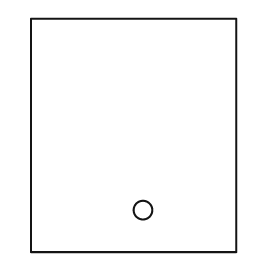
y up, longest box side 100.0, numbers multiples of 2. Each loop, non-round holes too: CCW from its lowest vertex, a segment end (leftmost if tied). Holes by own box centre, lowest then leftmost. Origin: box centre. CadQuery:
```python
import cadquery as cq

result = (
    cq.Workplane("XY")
    .moveTo(-44.0, -50.0)
    .lineTo(44.0, -50.0)
    .lineTo(44.0, 50.0)
    .lineTo(-44.0, 50.0)
    .close()
    .moveTo(4.0, -32.0)
    .circle(4.0)
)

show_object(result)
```